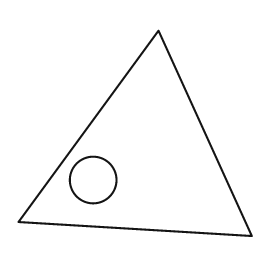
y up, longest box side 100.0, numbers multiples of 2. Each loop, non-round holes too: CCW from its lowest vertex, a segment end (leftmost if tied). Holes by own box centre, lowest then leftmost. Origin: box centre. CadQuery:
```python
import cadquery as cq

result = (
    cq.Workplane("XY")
    .moveTo(50.0, -44.0)
    .lineTo(10.0, 44.0)
    .lineTo(-50.0, -38.0)
    .close()
    .moveTo(-18.0, -20.0)
    .circle(10.0)
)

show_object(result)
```